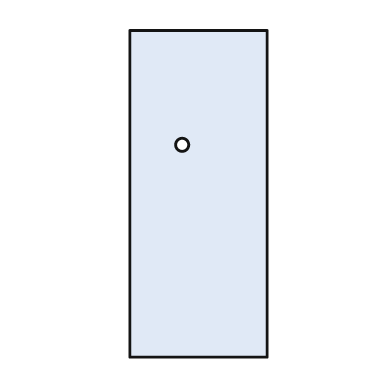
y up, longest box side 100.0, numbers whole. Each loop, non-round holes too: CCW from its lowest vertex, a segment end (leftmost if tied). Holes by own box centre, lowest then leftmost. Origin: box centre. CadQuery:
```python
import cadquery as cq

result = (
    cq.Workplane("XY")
    .moveTo(-21.0, -50.0)
    .lineTo(21.0, -50.0)
    .lineTo(21.0, 50.0)
    .lineTo(-21.0, 50.0)
    .close()
    .moveTo(-5.0, 15.0)
    .circle(2.0)
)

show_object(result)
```